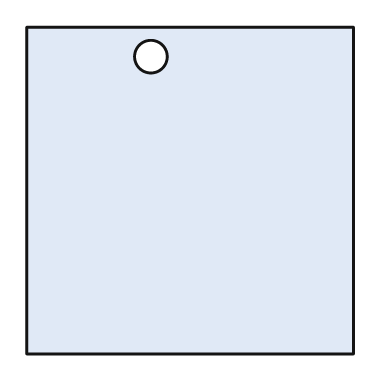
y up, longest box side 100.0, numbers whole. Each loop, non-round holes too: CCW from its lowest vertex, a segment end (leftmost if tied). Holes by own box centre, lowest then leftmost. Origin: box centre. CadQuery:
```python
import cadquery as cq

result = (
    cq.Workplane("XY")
    .moveTo(-50.0, -50.0)
    .lineTo(50.0, -50.0)
    .lineTo(50.0, 50.0)
    .lineTo(-50.0, 50.0)
    .close()
    .moveTo(-12.0, 41.0)
    .circle(5.0)
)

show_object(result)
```